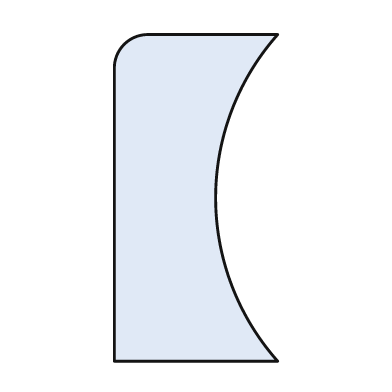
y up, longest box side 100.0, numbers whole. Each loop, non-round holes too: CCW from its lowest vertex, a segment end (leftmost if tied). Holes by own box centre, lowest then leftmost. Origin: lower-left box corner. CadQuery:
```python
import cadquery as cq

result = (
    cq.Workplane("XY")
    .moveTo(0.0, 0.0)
    .lineTo(50.0, 0.0)
    .threePointArc((31.0, 50.0), (50.0, 100.0))
    .lineTo(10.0, 100.0)
    .threePointArc((3.0, 97.0), (0.0, 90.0))
    .close()
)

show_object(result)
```